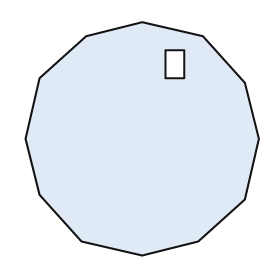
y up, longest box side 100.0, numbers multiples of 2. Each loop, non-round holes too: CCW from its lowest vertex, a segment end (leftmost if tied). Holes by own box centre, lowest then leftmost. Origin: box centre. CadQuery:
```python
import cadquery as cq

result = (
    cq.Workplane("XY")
    .moveTo(0.0, -50.0)
    .lineTo(24.0, -44.0)
    .lineTo(44.0, -26.0)
    .lineTo(50.0, 0.0)
    .lineTo(44.0, 24.0)
    .lineTo(26.0, 44.0)
    .lineTo(0.0, 50.0)
    .lineTo(-24.0, 44.0)
    .lineTo(-44.0, 26.0)
    .lineTo(-50.0, 0.0)
    .lineTo(-44.0, -24.0)
    .lineTo(-26.0, -44.0)
    .close()
    .moveTo(10.0, 26.0)
    .lineTo(18.0, 26.0)
    .lineTo(18.0, 38.0)
    .lineTo(10.0, 38.0)
    .close()
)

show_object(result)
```